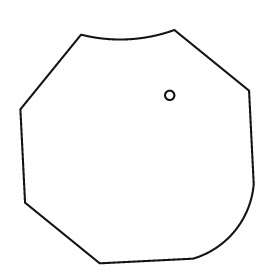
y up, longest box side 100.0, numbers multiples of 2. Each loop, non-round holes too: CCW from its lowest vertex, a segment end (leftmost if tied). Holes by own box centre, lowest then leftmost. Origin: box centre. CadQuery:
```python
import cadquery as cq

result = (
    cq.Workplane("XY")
    .moveTo(-16.0, -50.0)
    .lineTo(24.0, -48.0)
    .threePointArc((42.0, -36.0), (50.0, -16.0))
    .lineTo(48.0, 24.0)
    .lineTo(16.0, 50.0)
    .threePointArc((-4.0, 46.0), (-24.0, 48.0))
    .lineTo(-50.0, 16.0)
    .lineTo(-48.0, -24.0)
    .close()
    .moveTo(14.0, 22.0)
    .circle(2.0)
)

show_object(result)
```